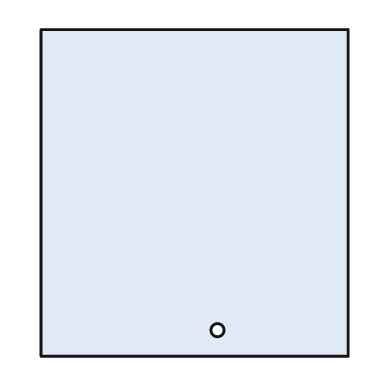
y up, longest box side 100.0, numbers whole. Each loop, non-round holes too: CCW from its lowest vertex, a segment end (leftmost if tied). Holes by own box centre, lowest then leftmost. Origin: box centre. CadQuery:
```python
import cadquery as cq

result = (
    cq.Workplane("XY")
    .moveTo(-47.0, -50.0)
    .lineTo(47.0, -50.0)
    .lineTo(47.0, 50.0)
    .lineTo(-47.0, 50.0)
    .close()
    .moveTo(7.0, -42.0)
    .circle(2.0)
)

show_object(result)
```